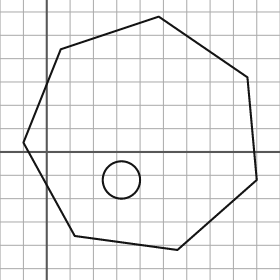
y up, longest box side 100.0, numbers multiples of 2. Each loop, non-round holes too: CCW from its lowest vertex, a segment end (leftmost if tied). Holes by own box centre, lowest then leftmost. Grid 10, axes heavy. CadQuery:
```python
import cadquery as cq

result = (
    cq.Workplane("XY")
    .moveTo(56.0, -42.0)
    .lineTo(90.0, -12.0)
    .lineTo(86.0, 32.0)
    .lineTo(48.0, 58.0)
    .lineTo(6.0, 44.0)
    .lineTo(-10.0, 4.0)
    .lineTo(12.0, -36.0)
    .close()
    .moveTo(32.0, -12.0)
    .circle(8.0)
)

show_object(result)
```